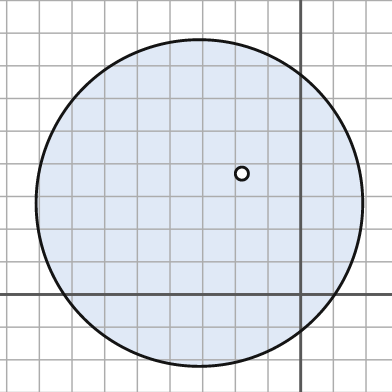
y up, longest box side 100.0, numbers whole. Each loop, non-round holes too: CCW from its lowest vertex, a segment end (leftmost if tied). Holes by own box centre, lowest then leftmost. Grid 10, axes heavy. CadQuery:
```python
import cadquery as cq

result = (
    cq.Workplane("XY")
    .moveTo(-31.0, 28.0)
    .circle(50.0)
    .moveTo(-18.0, 37.0)
    .circle(2.0)
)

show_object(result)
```